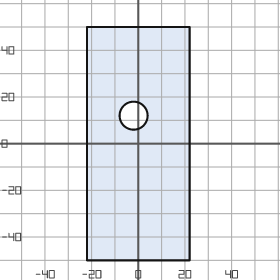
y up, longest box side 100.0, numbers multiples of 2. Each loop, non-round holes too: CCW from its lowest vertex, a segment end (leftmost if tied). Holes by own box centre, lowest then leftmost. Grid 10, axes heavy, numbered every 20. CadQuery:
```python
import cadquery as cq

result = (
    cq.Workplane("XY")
    .moveTo(-22.0, -50.0)
    .lineTo(22.0, -50.0)
    .lineTo(22.0, 50.0)
    .lineTo(-22.0, 50.0)
    .close()
    .moveTo(-2.0, 12.0)
    .circle(6.0)
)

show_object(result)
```